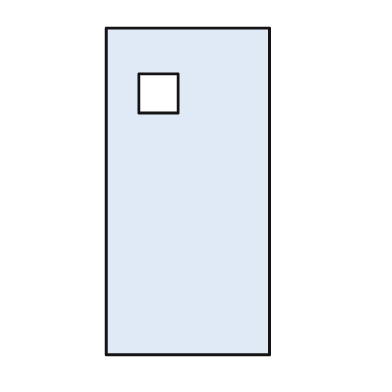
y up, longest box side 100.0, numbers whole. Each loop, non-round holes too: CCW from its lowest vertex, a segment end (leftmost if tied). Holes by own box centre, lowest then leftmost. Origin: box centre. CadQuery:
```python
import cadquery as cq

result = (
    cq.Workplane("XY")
    .moveTo(-25.0, -50.0)
    .lineTo(25.0, -50.0)
    .lineTo(25.0, 50.0)
    .lineTo(-25.0, 50.0)
    .close()
    .moveTo(-15.0, 24.0)
    .lineTo(-3.0, 24.0)
    .lineTo(-3.0, 36.0)
    .lineTo(-15.0, 36.0)
    .close()
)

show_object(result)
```